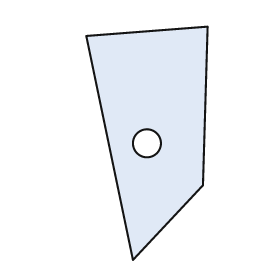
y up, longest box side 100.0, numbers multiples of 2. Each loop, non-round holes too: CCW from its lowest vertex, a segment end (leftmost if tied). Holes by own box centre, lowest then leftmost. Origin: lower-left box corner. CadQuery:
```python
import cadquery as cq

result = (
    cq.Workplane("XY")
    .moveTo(20.0, 0.0)
    .lineTo(50.0, 32.0)
    .lineTo(52.0, 100.0)
    .lineTo(0.0, 96.0)
    .close()
    .moveTo(26.0, 50.0)
    .circle(6.0)
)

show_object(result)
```